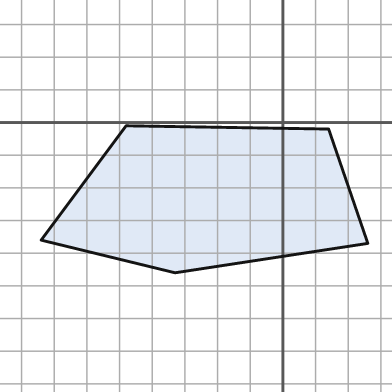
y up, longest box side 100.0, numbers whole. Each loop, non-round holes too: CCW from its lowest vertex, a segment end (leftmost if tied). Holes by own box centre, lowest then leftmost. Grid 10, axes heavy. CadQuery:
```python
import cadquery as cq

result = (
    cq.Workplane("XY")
    .moveTo(-33.0, -46.0)
    .lineTo(26.0, -37.0)
    .lineTo(14.0, -2.0)
    .lineTo(-48.0, -1.0)
    .lineTo(-74.0, -36.0)
    .close()
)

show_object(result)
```